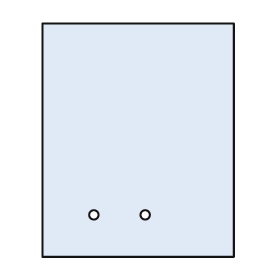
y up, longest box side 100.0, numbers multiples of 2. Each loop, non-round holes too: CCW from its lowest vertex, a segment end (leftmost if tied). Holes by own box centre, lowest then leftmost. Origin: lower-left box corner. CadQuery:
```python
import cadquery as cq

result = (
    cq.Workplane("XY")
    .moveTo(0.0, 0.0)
    .lineTo(82.0, 0.0)
    .lineTo(82.0, 100.0)
    .lineTo(0.0, 100.0)
    .close()
    .moveTo(22.0, 18.0)
    .circle(2.0)
    .moveTo(44.0, 18.0)
    .circle(2.0)
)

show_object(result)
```